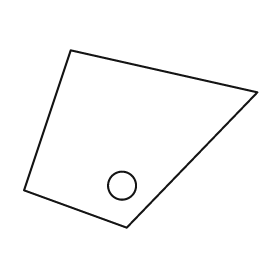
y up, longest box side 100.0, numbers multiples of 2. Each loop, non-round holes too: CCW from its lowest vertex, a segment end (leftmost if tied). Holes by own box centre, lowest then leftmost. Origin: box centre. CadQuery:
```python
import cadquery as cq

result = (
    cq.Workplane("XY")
    .moveTo(-6.0, -38.0)
    .lineTo(50.0, 20.0)
    .lineTo(-30.0, 38.0)
    .lineTo(-50.0, -22.0)
    .close()
    .moveTo(-8.0, -20.0)
    .circle(6.0)
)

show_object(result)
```